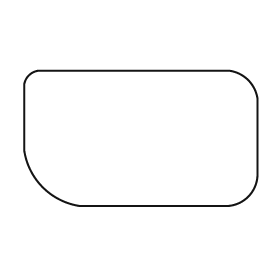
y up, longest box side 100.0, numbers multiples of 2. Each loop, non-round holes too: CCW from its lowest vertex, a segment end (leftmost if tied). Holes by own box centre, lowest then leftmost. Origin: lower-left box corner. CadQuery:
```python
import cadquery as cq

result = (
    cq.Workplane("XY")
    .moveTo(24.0, 0.0)
    .lineTo(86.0, 0.0)
    .threePointArc((96.0, 4.0), (100.0, 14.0))
    .lineTo(100.0, 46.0)
    .threePointArc((96.0, 54.0), (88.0, 58.0))
    .lineTo(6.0, 58.0)
    .threePointArc((2.0, 56.0), (0.0, 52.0))
    .lineTo(0.0, 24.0)
    .threePointArc((8.0, 8.0), (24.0, 0.0))
    .close()
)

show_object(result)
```